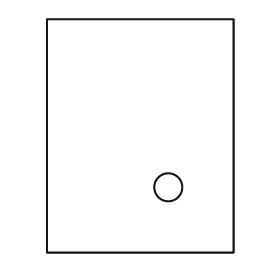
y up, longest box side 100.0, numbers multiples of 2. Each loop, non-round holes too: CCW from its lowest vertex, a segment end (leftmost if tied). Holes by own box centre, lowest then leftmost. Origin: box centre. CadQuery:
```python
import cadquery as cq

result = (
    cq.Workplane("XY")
    .moveTo(-40.0, -50.0)
    .lineTo(40.0, -50.0)
    .lineTo(40.0, 50.0)
    .lineTo(-40.0, 50.0)
    .close()
    .moveTo(12.0, -22.0)
    .circle(6.0)
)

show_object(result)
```